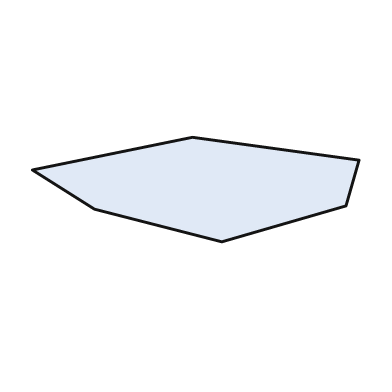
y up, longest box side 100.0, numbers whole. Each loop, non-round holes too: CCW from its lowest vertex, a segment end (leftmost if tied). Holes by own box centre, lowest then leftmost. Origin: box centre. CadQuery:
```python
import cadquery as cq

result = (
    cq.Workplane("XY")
    .moveTo(8.0, -16.0)
    .lineTo(46.0, -5.0)
    .lineTo(50.0, 9.0)
    .lineTo(-1.0, 16.0)
    .lineTo(-50.0, 6.0)
    .lineTo(-31.0, -6.0)
    .close()
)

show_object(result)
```